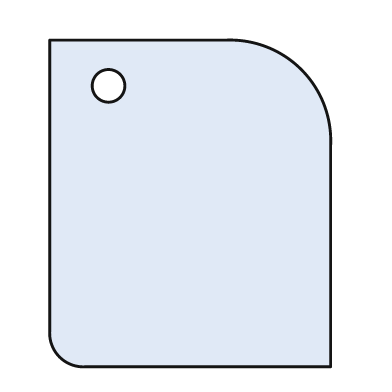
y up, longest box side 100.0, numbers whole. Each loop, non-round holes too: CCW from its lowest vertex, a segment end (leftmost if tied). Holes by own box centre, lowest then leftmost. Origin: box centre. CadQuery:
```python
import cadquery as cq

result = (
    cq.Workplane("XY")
    .moveTo(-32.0, -50.0)
    .lineTo(43.0, -50.0)
    .lineTo(43.0, 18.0)
    .threePointArc((34.0, 41.0), (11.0, 50.0))
    .lineTo(-43.0, 50.0)
    .lineTo(-43.0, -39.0)
    .threePointArc((-40.0, -47.0), (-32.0, -50.0))
    .close()
    .moveTo(-25.0, 36.0)
    .circle(5.0)
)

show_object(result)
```